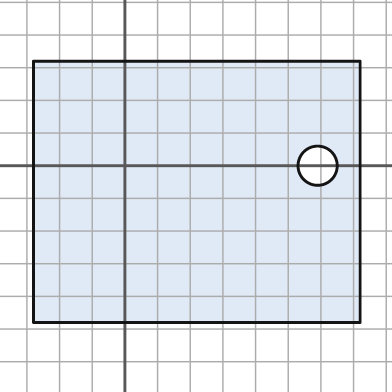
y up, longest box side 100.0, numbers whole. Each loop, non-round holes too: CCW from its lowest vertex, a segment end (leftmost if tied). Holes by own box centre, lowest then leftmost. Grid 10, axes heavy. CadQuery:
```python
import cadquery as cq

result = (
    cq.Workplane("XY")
    .moveTo(-28.0, -48.0)
    .lineTo(72.0, -48.0)
    .lineTo(72.0, 32.0)
    .lineTo(-28.0, 32.0)
    .close()
    .moveTo(59.0, 0.0)
    .circle(6.0)
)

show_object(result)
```